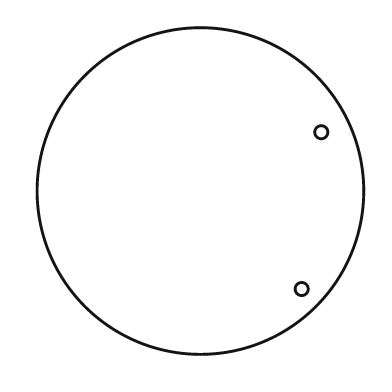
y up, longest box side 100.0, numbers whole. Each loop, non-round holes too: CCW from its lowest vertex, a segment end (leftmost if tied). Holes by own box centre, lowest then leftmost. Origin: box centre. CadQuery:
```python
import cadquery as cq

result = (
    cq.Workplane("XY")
    .moveTo(0.0, 0.0)
    .circle(50.0)
    .moveTo(31.0, -30.0)
    .circle(2.0)
    .moveTo(37.0, 18.0)
    .circle(2.0)
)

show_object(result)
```